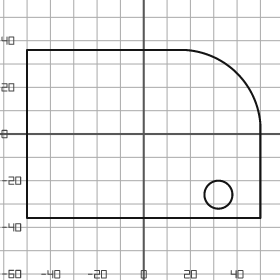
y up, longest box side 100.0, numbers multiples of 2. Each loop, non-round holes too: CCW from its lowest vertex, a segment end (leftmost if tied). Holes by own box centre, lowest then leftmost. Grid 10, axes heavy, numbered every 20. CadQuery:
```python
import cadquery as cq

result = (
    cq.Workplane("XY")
    .moveTo(-50.0, -36.0)
    .lineTo(50.0, -36.0)
    .lineTo(50.0, 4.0)
    .threePointArc((40.0, 26.0), (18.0, 36.0))
    .lineTo(-50.0, 36.0)
    .close()
    .moveTo(32.0, -26.0)
    .circle(6.0)
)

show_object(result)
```